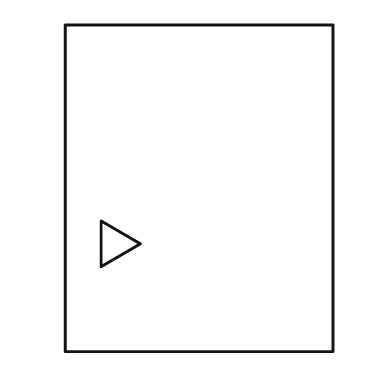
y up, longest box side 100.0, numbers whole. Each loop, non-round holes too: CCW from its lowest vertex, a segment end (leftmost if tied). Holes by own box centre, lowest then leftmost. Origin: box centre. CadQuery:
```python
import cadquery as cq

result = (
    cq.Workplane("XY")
    .moveTo(-41.0, -50.0)
    .lineTo(41.0, -50.0)
    .lineTo(41.0, 50.0)
    .lineTo(-41.0, 50.0)
    .close()
    .moveTo(-30.0, -24.0)
    .lineTo(-18.0, -17.0)
    .lineTo(-30.0, -10.0)
    .close()
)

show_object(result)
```